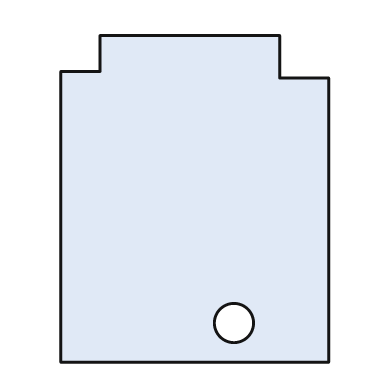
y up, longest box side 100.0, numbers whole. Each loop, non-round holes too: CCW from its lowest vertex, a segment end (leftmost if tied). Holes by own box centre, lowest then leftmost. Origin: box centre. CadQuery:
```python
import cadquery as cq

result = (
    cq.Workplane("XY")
    .moveTo(-41.0, -50.0)
    .lineTo(41.0, -50.0)
    .lineTo(41.0, 37.0)
    .lineTo(26.0, 37.0)
    .lineTo(26.0, 50.0)
    .lineTo(-29.0, 50.0)
    .lineTo(-29.0, 39.0)
    .lineTo(-41.0, 39.0)
    .close()
    .moveTo(12.0, -38.0)
    .circle(6.0)
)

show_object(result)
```